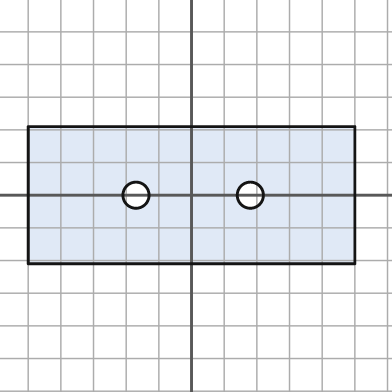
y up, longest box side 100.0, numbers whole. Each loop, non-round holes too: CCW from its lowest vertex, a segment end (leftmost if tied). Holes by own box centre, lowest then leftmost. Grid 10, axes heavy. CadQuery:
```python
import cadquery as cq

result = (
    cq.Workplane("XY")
    .moveTo(-50.0, -21.0)
    .lineTo(50.0, -21.0)
    .lineTo(50.0, 21.0)
    .lineTo(-50.0, 21.0)
    .close()
    .moveTo(-17.0, 0.0)
    .circle(4.0)
    .moveTo(18.0, 0.0)
    .circle(4.0)
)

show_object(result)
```